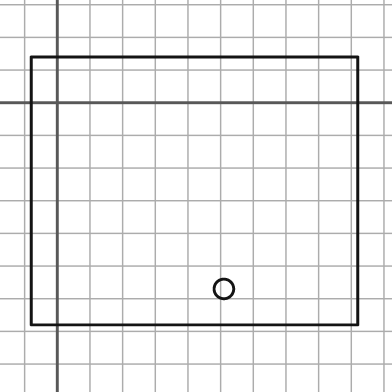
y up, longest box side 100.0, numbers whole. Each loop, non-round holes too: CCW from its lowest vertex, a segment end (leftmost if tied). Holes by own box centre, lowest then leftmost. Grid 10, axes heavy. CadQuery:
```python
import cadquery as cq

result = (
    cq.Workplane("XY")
    .moveTo(-8.0, -68.0)
    .lineTo(92.0, -68.0)
    .lineTo(92.0, 14.0)
    .lineTo(-8.0, 14.0)
    .close()
    .moveTo(51.0, -57.0)
    .circle(3.0)
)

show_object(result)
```